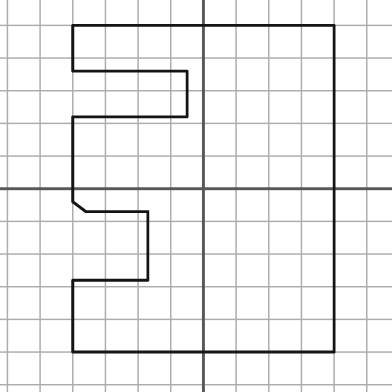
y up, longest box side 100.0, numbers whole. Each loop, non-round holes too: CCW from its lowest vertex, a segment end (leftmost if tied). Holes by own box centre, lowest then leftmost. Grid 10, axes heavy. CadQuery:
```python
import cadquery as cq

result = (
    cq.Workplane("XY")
    .moveTo(-40.0, -50.0)
    .lineTo(40.0, -50.0)
    .lineTo(40.0, 50.0)
    .lineTo(-40.0, 50.0)
    .lineTo(-40.0, 36.0)
    .lineTo(-5.0, 36.0)
    .lineTo(-5.0, 22.0)
    .lineTo(-40.0, 22.0)
    .lineTo(-40.0, -4.0)
    .lineTo(-36.0, -7.0)
    .lineTo(-17.0, -7.0)
    .lineTo(-17.0, -28.0)
    .lineTo(-40.0, -28.0)
    .close()
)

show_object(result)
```